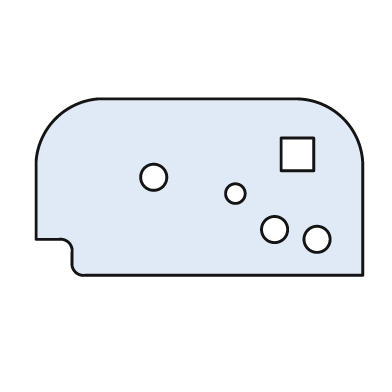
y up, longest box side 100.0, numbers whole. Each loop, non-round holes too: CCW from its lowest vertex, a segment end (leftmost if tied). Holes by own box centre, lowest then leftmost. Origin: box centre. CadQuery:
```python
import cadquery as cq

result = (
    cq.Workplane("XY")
    .moveTo(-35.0, -27.0)
    .lineTo(50.0, -27.0)
    .lineTo(50.0, 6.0)
    .threePointArc((44.0, 21.0), (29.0, 27.0))
    .lineTo(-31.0, 27.0)
    .threePointArc((-44.0, 21.0), (-50.0, 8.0))
    .lineTo(-50.0, -16.0)
    .lineTo(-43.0, -16.0)
    .threePointArc((-40.0, -17.0), (-39.0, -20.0))
    .lineTo(-39.0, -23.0)
    .threePointArc((-38.0, -26.0), (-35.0, -27.0))
    .close()
    .moveTo(36.0, -16.0)
    .circle(4.0)
    .moveTo(23.0, -13.0)
    .circle(4.0)
    .moveTo(11.0, -2.0)
    .circle(3.0)
    .moveTo(-14.0, 3.0)
    .circle(4.0)
    .moveTo(25.0, 5.0)
    .lineTo(35.0, 5.0)
    .lineTo(35.0, 15.0)
    .lineTo(25.0, 15.0)
    .close()
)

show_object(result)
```